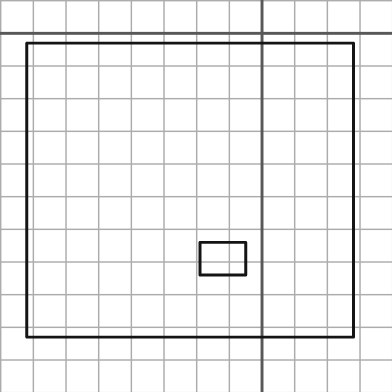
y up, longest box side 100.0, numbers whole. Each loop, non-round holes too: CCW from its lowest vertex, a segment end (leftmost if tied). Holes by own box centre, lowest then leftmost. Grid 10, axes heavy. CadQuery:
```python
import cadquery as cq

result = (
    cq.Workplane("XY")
    .moveTo(-72.0, -93.0)
    .lineTo(28.0, -93.0)
    .lineTo(28.0, -3.0)
    .lineTo(-72.0, -3.0)
    .close()
    .moveTo(-19.0, -74.0)
    .lineTo(-5.0, -74.0)
    .lineTo(-5.0, -64.0)
    .lineTo(-19.0, -64.0)
    .close()
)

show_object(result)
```